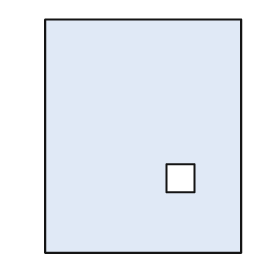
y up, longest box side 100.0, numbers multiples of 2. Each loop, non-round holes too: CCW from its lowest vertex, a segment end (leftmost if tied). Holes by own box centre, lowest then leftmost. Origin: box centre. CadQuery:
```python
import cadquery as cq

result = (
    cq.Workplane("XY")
    .moveTo(-42.0, -50.0)
    .lineTo(42.0, -50.0)
    .lineTo(42.0, 50.0)
    .lineTo(-42.0, 50.0)
    .close()
    .moveTo(10.0, -24.0)
    .lineTo(22.0, -24.0)
    .lineTo(22.0, -12.0)
    .lineTo(10.0, -12.0)
    .close()
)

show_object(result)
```